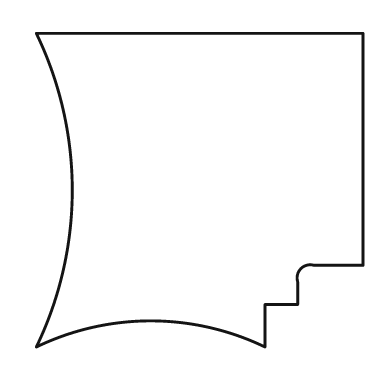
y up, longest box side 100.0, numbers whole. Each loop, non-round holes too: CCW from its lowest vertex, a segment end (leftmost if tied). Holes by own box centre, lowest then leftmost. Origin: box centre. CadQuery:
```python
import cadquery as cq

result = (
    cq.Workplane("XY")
    .moveTo(-50.0, -48.0)
    .threePointArc((-15.0, -40.0), (20.0, -48.0))
    .lineTo(20.0, -35.0)
    .lineTo(30.0, -35.0)
    .lineTo(30.0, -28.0)
    .threePointArc((31.0, -24.0), (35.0, -23.0))
    .lineTo(50.0, -23.0)
    .lineTo(50.0, 48.0)
    .lineTo(-50.0, 48.0)
    .threePointArc((-39.0, 0.0), (-50.0, -48.0))
    .close()
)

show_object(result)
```